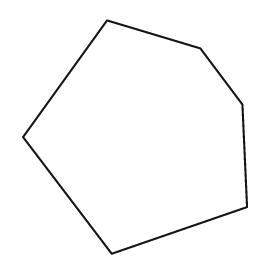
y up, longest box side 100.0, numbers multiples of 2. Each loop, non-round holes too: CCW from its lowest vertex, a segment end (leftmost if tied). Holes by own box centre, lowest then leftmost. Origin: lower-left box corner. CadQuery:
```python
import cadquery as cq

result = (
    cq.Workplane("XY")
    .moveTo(38.0, 0.0)
    .lineTo(96.0, 20.0)
    .lineTo(94.0, 64.0)
    .lineTo(76.0, 88.0)
    .lineTo(36.0, 100.0)
    .lineTo(0.0, 50.0)
    .close()
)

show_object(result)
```